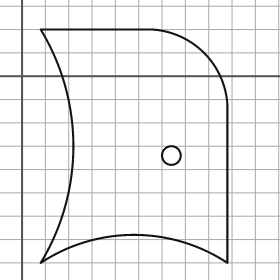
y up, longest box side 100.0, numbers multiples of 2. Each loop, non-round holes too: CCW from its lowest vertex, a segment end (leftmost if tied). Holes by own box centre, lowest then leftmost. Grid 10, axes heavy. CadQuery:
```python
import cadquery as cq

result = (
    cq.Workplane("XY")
    .moveTo(8.0, -80.0)
    .threePointArc((48.0, -68.0), (88.0, -80.0))
    .lineTo(88.0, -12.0)
    .threePointArc((78.0, 10.0), (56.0, 20.0))
    .lineTo(8.0, 20.0)
    .threePointArc((22.0, -30.0), (8.0, -80.0))
    .close()
    .moveTo(64.0, -34.0)
    .circle(4.0)
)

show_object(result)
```